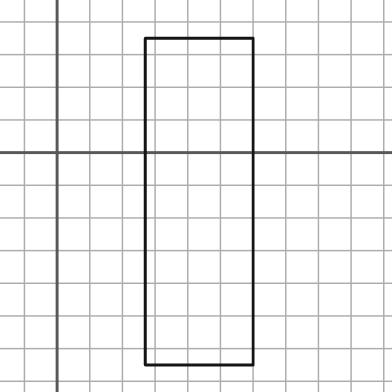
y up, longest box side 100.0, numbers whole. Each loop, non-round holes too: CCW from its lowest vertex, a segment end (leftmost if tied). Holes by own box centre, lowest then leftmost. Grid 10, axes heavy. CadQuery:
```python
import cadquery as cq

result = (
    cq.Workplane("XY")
    .moveTo(27.0, -65.0)
    .lineTo(60.0, -65.0)
    .lineTo(60.0, 35.0)
    .lineTo(27.0, 35.0)
    .close()
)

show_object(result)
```